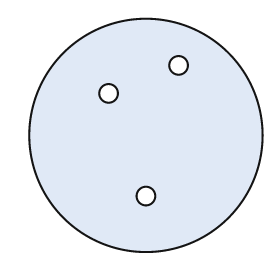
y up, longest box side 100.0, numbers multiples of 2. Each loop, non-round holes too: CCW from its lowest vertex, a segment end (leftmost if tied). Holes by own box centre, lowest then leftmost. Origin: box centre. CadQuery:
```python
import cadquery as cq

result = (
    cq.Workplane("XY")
    .moveTo(0.0, 0.0)
    .circle(50.0)
    .moveTo(0.0, -26.0)
    .circle(4.0)
    .moveTo(-16.0, 18.0)
    .circle(4.0)
    .moveTo(14.0, 30.0)
    .circle(4.0)
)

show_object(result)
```